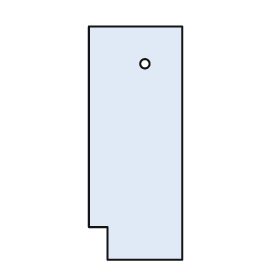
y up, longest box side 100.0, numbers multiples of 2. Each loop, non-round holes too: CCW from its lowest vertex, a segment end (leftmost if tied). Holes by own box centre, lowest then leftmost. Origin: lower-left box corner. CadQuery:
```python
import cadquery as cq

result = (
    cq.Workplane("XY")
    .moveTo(8.0, 0.0)
    .lineTo(40.0, 0.0)
    .lineTo(40.0, 100.0)
    .lineTo(0.0, 100.0)
    .lineTo(0.0, 14.0)
    .lineTo(8.0, 14.0)
    .close()
    .moveTo(24.0, 84.0)
    .circle(2.0)
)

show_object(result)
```